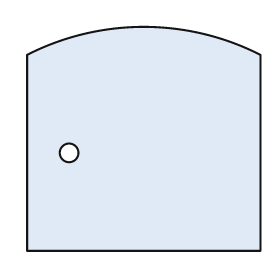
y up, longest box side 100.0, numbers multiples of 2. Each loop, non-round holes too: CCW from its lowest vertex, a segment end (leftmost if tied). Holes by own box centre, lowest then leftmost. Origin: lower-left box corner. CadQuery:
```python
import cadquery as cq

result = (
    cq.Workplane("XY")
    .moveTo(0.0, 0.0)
    .lineTo(100.0, 0.0)
    .lineTo(100.0, 84.0)
    .threePointArc((50.0, 96.0), (0.0, 84.0))
    .close()
    .moveTo(18.0, 42.0)
    .circle(4.0)
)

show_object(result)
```